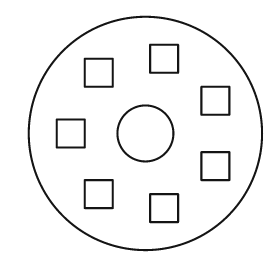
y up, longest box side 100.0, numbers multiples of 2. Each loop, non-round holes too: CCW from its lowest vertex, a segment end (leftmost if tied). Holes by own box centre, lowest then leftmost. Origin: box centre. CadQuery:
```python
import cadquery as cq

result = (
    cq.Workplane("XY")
    .moveTo(0.0, 0.0)
    .circle(50.0)
    .moveTo(2.0, -38.0)
    .lineTo(14.0, -38.0)
    .lineTo(14.0, -26.0)
    .lineTo(2.0, -26.0)
    .close()
    .moveTo(-26.0, -32.0)
    .lineTo(-14.0, -32.0)
    .lineTo(-14.0, -20.0)
    .lineTo(-26.0, -20.0)
    .close()
    .moveTo(24.0, -20.0)
    .lineTo(36.0, -20.0)
    .lineTo(36.0, -8.0)
    .lineTo(24.0, -8.0)
    .close()
    .moveTo(-38.0, -6.0)
    .lineTo(-26.0, -6.0)
    .lineTo(-26.0, 6.0)
    .lineTo(-38.0, 6.0)
    .close()
    .moveTo(0.0, 0.0)
    .circle(12.0)
    .moveTo(24.0, 8.0)
    .lineTo(36.0, 8.0)
    .lineTo(36.0, 20.0)
    .lineTo(24.0, 20.0)
    .close()
    .moveTo(-26.0, 20.0)
    .lineTo(-14.0, 20.0)
    .lineTo(-14.0, 32.0)
    .lineTo(-26.0, 32.0)
    .close()
    .moveTo(2.0, 26.0)
    .lineTo(14.0, 26.0)
    .lineTo(14.0, 38.0)
    .lineTo(2.0, 38.0)
    .close()
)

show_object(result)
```